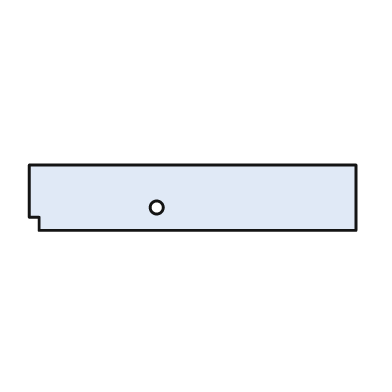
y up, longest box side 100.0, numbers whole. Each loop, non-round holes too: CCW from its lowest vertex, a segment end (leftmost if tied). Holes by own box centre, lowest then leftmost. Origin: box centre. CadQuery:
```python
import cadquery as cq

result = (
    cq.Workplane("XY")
    .moveTo(-47.0, -10.0)
    .lineTo(50.0, -10.0)
    .lineTo(50.0, 10.0)
    .lineTo(-50.0, 10.0)
    .lineTo(-50.0, -6.0)
    .lineTo(-47.0, -6.0)
    .close()
    .moveTo(-11.0, -3.0)
    .circle(2.0)
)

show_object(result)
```